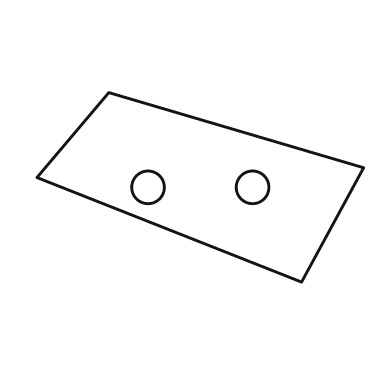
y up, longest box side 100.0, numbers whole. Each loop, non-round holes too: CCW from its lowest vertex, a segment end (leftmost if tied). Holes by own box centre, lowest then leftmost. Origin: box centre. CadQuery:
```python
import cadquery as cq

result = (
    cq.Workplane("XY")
    .moveTo(31.0, -29.0)
    .lineTo(50.0, 6.0)
    .lineTo(-28.0, 29.0)
    .lineTo(-50.0, 3.0)
    .close()
    .moveTo(-16.0, 0.0)
    .circle(5.0)
    .moveTo(16.0, 0.0)
    .circle(5.0)
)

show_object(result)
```